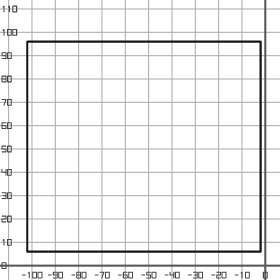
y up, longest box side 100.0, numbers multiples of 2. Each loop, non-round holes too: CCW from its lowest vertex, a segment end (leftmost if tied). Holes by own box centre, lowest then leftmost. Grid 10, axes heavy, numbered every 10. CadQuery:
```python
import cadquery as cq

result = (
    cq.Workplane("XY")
    .moveTo(-102.0, 6.0)
    .lineTo(-2.0, 6.0)
    .lineTo(-2.0, 96.0)
    .lineTo(-102.0, 96.0)
    .close()
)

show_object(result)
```